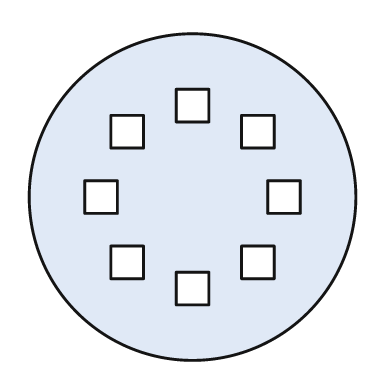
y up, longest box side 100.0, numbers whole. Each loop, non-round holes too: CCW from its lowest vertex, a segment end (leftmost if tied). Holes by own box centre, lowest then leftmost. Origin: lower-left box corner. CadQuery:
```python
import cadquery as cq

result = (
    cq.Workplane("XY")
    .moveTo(50.0, 50.0)
    .circle(50.0)
    .moveTo(45.0, 17.0)
    .lineTo(55.0, 17.0)
    .lineTo(55.0, 27.0)
    .lineTo(45.0, 27.0)
    .close()
    .moveTo(25.0, 25.0)
    .lineTo(35.0, 25.0)
    .lineTo(35.0, 35.0)
    .lineTo(25.0, 35.0)
    .close()
    .moveTo(65.0, 25.0)
    .lineTo(75.0, 25.0)
    .lineTo(75.0, 35.0)
    .lineTo(65.0, 35.0)
    .close()
    .moveTo(17.0, 45.0)
    .lineTo(27.0, 45.0)
    .lineTo(27.0, 55.0)
    .lineTo(17.0, 55.0)
    .close()
    .moveTo(73.0, 45.0)
    .lineTo(83.0, 45.0)
    .lineTo(83.0, 55.0)
    .lineTo(73.0, 55.0)
    .close()
    .moveTo(25.0, 65.0)
    .lineTo(35.0, 65.0)
    .lineTo(35.0, 75.0)
    .lineTo(25.0, 75.0)
    .close()
    .moveTo(65.0, 65.0)
    .lineTo(75.0, 65.0)
    .lineTo(75.0, 75.0)
    .lineTo(65.0, 75.0)
    .close()
    .moveTo(45.0, 73.0)
    .lineTo(55.0, 73.0)
    .lineTo(55.0, 83.0)
    .lineTo(45.0, 83.0)
    .close()
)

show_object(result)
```